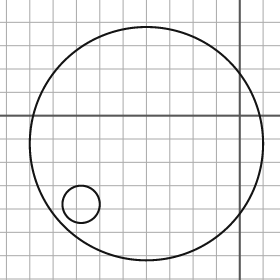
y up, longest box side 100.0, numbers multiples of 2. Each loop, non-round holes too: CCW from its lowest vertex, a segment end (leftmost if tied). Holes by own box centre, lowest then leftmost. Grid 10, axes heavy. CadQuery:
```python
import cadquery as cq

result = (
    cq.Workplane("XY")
    .moveTo(-40.0, -12.0)
    .circle(50.0)
    .moveTo(-68.0, -38.0)
    .circle(8.0)
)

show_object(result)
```